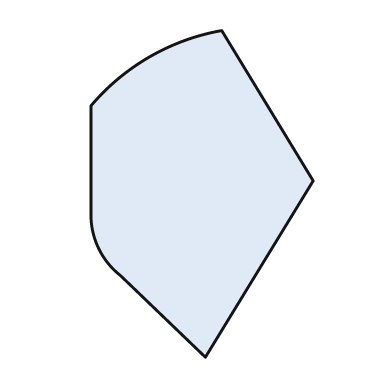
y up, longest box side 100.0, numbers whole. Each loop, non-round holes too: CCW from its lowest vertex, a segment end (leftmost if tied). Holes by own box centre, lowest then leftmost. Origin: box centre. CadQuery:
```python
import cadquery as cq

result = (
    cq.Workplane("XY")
    .moveTo(1.0, -50.0)
    .lineTo(34.0, 4.0)
    .lineTo(6.0, 50.0)
    .threePointArc((-16.0, 42.0), (-34.0, 27.0))
    .lineTo(-34.0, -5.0)
    .threePointArc((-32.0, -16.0), (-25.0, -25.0))
    .close()
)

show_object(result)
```